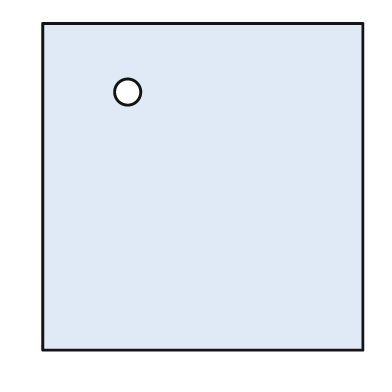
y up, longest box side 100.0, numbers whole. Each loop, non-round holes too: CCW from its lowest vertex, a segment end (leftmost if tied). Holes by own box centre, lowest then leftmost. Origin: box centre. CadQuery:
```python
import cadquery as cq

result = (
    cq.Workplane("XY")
    .moveTo(-49.0, -50.0)
    .lineTo(49.0, -50.0)
    .lineTo(49.0, 50.0)
    .lineTo(-49.0, 50.0)
    .close()
    .moveTo(-23.0, 29.0)
    .circle(4.0)
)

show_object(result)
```